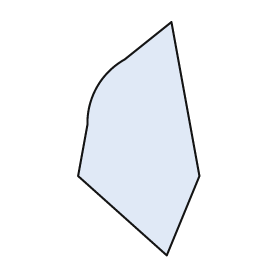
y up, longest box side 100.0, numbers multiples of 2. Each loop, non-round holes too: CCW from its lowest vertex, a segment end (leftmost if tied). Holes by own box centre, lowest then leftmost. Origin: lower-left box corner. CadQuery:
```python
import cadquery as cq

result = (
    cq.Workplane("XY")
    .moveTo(38.0, 0.0)
    .lineTo(52.0, 34.0)
    .lineTo(40.0, 100.0)
    .lineTo(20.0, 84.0)
    .threePointArc((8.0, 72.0), (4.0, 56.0))
    .lineTo(0.0, 34.0)
    .close()
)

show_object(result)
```